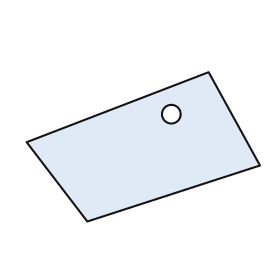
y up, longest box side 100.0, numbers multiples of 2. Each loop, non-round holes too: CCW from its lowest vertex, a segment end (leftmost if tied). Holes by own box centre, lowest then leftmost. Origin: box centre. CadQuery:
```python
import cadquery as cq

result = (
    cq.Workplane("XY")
    .moveTo(-24.0, -32.0)
    .lineTo(50.0, -8.0)
    .lineTo(28.0, 32.0)
    .lineTo(-50.0, 2.0)
    .close()
    .moveTo(12.0, 14.0)
    .circle(4.0)
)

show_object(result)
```